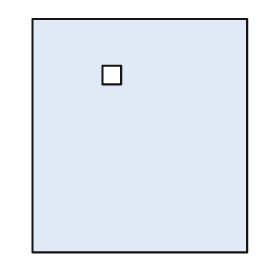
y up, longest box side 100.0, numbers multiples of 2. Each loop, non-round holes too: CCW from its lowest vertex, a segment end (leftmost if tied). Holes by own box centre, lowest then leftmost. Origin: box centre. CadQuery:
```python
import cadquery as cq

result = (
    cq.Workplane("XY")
    .moveTo(-46.0, -50.0)
    .lineTo(46.0, -50.0)
    .lineTo(46.0, 50.0)
    .lineTo(-46.0, 50.0)
    .close()
    .moveTo(-16.0, 22.0)
    .lineTo(-8.0, 22.0)
    .lineTo(-8.0, 30.0)
    .lineTo(-16.0, 30.0)
    .close()
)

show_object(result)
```